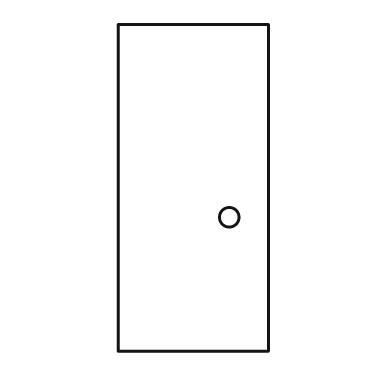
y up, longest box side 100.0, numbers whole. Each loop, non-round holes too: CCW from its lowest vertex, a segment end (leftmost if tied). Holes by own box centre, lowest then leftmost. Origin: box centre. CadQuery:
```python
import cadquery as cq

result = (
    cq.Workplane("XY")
    .moveTo(-23.0, -50.0)
    .lineTo(23.0, -50.0)
    .lineTo(23.0, 50.0)
    .lineTo(-23.0, 50.0)
    .close()
    .moveTo(11.0, -9.0)
    .circle(3.0)
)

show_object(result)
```